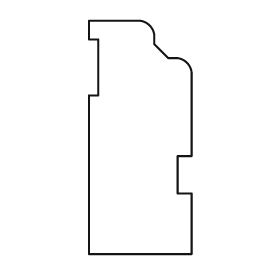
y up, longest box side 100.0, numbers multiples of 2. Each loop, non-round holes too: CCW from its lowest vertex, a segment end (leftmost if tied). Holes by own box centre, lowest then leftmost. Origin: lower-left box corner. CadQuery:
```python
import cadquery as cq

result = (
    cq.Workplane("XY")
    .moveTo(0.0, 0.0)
    .lineTo(44.0, 0.0)
    .lineTo(44.0, 26.0)
    .lineTo(38.0, 26.0)
    .lineTo(38.0, 42.0)
    .lineTo(44.0, 42.0)
    .lineTo(44.0, 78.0)
    .threePointArc((42.0, 82.0), (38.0, 84.0))
    .lineTo(34.0, 84.0)
    .lineTo(28.0, 90.0)
    .lineTo(28.0, 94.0)
    .threePointArc((26.0, 98.0), (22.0, 100.0))
    .lineTo(0.0, 100.0)
    .lineTo(0.0, 92.0)
    .lineTo(4.0, 92.0)
    .lineTo(4.0, 68.0)
    .lineTo(0.0, 68.0)
    .close()
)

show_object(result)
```